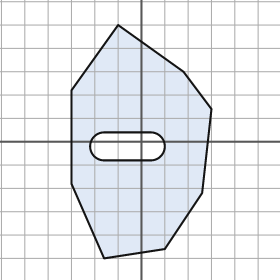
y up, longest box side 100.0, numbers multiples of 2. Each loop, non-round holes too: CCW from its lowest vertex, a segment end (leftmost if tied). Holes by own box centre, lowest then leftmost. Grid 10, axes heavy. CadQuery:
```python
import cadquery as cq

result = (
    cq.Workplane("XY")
    .moveTo(-16.0, -50.0)
    .lineTo(10.0, -46.0)
    .lineTo(26.0, -22.0)
    .lineTo(30.0, 14.0)
    .lineTo(18.0, 30.0)
    .lineTo(-10.0, 50.0)
    .lineTo(-30.0, 22.0)
    .lineTo(-30.0, -18.0)
    .close()
    .moveTo(-16.0, -8.0)
    .lineTo(4.0, -8.0)
    .threePointArc((10.0, -2.0), (4.0, 4.0))
    .lineTo(-16.0, 4.0)
    .threePointArc((-22.0, -2.0), (-16.0, -8.0))
    .close()
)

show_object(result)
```